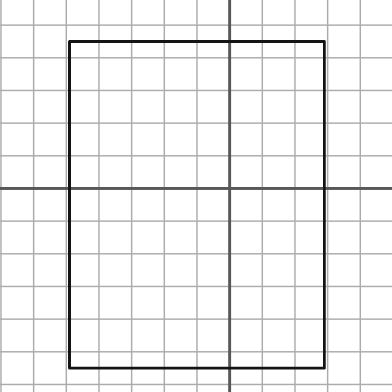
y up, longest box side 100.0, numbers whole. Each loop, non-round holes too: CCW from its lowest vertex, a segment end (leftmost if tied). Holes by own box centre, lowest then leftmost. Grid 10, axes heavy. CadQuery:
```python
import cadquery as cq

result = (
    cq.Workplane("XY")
    .moveTo(-49.0, -55.0)
    .lineTo(29.0, -55.0)
    .lineTo(29.0, 45.0)
    .lineTo(-49.0, 45.0)
    .close()
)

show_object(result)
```